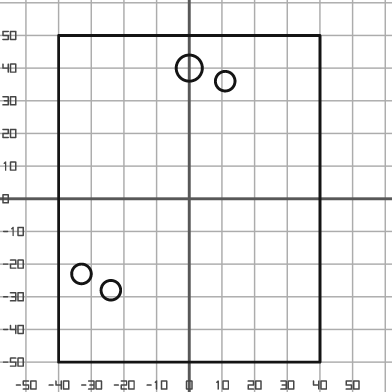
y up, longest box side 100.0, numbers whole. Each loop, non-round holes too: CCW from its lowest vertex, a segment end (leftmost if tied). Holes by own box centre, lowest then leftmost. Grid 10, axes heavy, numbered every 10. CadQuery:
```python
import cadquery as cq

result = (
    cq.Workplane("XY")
    .moveTo(-40.0, -50.0)
    .lineTo(40.0, -50.0)
    .lineTo(40.0, 50.0)
    .lineTo(-40.0, 50.0)
    .close()
    .moveTo(-24.0, -28.0)
    .circle(3.0)
    .moveTo(-33.0, -23.0)
    .circle(3.0)
    .moveTo(11.0, 36.0)
    .circle(3.0)
    .moveTo(0.0, 40.0)
    .circle(4.0)
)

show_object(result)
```